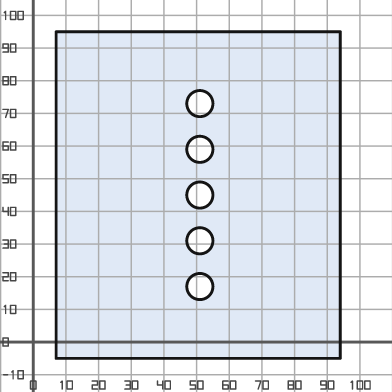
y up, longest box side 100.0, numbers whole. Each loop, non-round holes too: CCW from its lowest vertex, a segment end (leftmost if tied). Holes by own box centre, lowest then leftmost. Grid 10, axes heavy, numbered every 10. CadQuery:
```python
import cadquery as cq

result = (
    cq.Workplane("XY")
    .moveTo(7.0, -5.0)
    .lineTo(94.0, -5.0)
    .lineTo(94.0, 95.0)
    .lineTo(7.0, 95.0)
    .close()
    .moveTo(51.0, 17.0)
    .circle(4.0)
    .moveTo(51.0, 31.0)
    .circle(4.0)
    .moveTo(51.0, 45.0)
    .circle(4.0)
    .moveTo(51.0, 59.0)
    .circle(4.0)
    .moveTo(51.0, 73.0)
    .circle(4.0)
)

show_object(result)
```